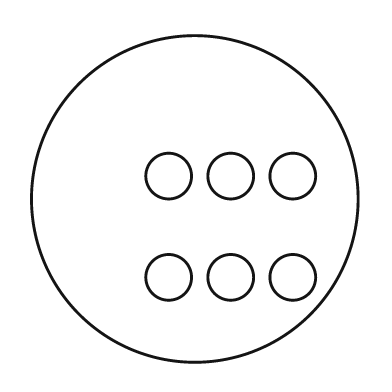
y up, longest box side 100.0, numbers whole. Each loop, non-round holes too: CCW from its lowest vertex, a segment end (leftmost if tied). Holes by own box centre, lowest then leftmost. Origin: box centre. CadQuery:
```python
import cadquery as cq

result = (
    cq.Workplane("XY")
    .moveTo(0.0, 0.0)
    .circle(50.0)
    .moveTo(-8.0, -24.0)
    .circle(7.0)
    .moveTo(11.0, -24.0)
    .circle(7.0)
    .moveTo(30.0, -24.0)
    .circle(7.0)
    .moveTo(-8.0, 7.0)
    .circle(7.0)
    .moveTo(11.0, 7.0)
    .circle(7.0)
    .moveTo(30.0, 7.0)
    .circle(7.0)
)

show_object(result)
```